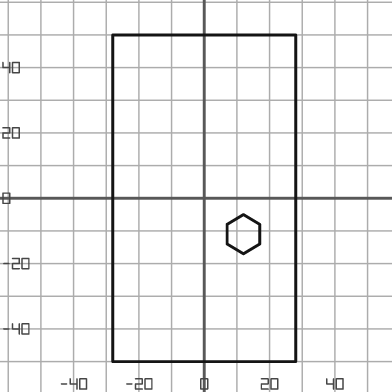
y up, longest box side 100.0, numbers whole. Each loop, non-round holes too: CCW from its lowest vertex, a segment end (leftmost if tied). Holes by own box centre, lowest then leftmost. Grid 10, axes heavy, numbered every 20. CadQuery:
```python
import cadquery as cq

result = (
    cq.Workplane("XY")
    .moveTo(-28.0, -50.0)
    .lineTo(28.0, -50.0)
    .lineTo(28.0, 50.0)
    .lineTo(-28.0, 50.0)
    .close()
    .moveTo(12.0, -17.0)
    .lineTo(17.0, -14.0)
    .lineTo(17.0, -8.0)
    .lineTo(12.0, -5.0)
    .lineTo(7.0, -8.0)
    .lineTo(7.0, -14.0)
    .close()
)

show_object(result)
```